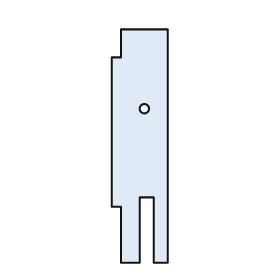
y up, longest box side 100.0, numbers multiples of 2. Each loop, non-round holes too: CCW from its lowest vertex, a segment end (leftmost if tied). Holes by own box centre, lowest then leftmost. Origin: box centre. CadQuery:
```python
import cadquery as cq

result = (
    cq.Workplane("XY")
    .moveTo(-8.0, -50.0)
    .lineTo(0.0, -50.0)
    .lineTo(0.0, -22.0)
    .lineTo(6.0, -22.0)
    .lineTo(6.0, -50.0)
    .lineTo(12.0, -50.0)
    .lineTo(12.0, 50.0)
    .lineTo(-8.0, 50.0)
    .lineTo(-8.0, 38.0)
    .lineTo(-12.0, 38.0)
    .lineTo(-12.0, -26.0)
    .lineTo(-8.0, -26.0)
    .close()
    .moveTo(2.0, 16.0)
    .circle(2.0)
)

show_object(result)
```